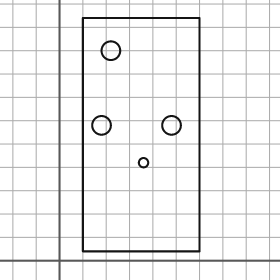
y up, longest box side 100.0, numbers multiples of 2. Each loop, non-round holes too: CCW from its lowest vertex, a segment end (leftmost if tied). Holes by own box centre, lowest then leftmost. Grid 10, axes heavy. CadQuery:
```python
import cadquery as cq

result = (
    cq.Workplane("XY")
    .moveTo(10.0, 4.0)
    .lineTo(60.0, 4.0)
    .lineTo(60.0, 104.0)
    .lineTo(10.0, 104.0)
    .close()
    .moveTo(36.0, 42.0)
    .circle(2.0)
    .moveTo(18.0, 58.0)
    .circle(4.0)
    .moveTo(48.0, 58.0)
    .circle(4.0)
    .moveTo(22.0, 90.0)
    .circle(4.0)
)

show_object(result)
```